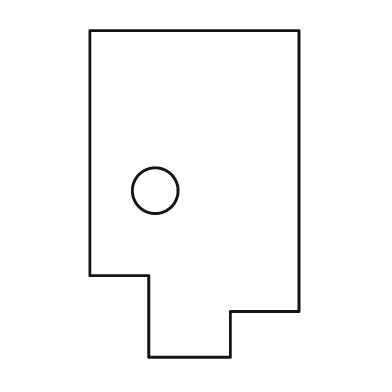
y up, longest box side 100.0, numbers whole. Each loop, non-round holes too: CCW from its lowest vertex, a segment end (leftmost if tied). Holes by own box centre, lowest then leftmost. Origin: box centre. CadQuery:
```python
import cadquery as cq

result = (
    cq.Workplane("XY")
    .moveTo(-14.0, -50.0)
    .lineTo(11.0, -50.0)
    .lineTo(11.0, -36.0)
    .lineTo(32.0, -36.0)
    .lineTo(32.0, 50.0)
    .lineTo(-32.0, 50.0)
    .lineTo(-32.0, -25.0)
    .lineTo(-14.0, -25.0)
    .close()
    .moveTo(-12.0, 1.0)
    .circle(7.0)
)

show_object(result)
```